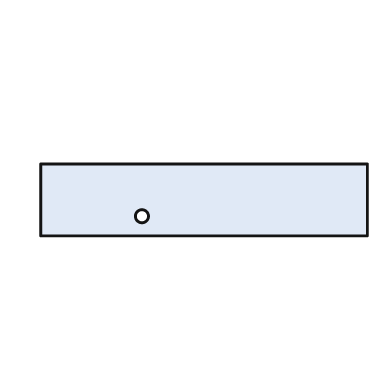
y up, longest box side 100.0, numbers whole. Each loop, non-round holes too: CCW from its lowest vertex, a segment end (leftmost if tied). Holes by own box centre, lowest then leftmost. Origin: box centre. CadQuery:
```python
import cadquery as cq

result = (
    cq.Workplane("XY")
    .moveTo(-50.0, -11.0)
    .lineTo(50.0, -11.0)
    .lineTo(50.0, 11.0)
    .lineTo(-50.0, 11.0)
    .close()
    .moveTo(-19.0, -5.0)
    .circle(2.0)
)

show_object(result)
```